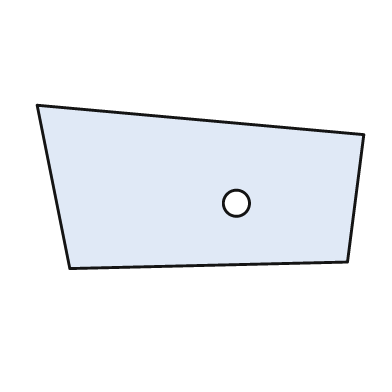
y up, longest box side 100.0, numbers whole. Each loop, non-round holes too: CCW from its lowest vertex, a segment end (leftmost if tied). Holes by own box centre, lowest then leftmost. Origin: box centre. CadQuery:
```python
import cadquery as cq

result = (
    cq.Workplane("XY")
    .moveTo(-40.0, -25.0)
    .lineTo(45.0, -23.0)
    .lineTo(50.0, 16.0)
    .lineTo(-50.0, 25.0)
    .close()
    .moveTo(11.0, -5.0)
    .circle(4.0)
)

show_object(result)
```